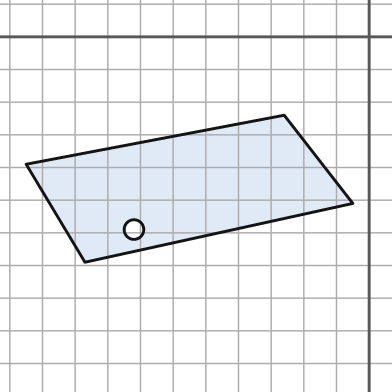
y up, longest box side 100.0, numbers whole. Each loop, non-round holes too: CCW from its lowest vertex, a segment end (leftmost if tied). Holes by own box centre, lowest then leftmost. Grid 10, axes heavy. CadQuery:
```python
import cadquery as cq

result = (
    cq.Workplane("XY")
    .moveTo(-87.0, -69.0)
    .lineTo(-5.0, -51.0)
    .lineTo(-26.0, -24.0)
    .lineTo(-105.0, -39.0)
    .close()
    .moveTo(-72.0, -59.0)
    .circle(3.0)
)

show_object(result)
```